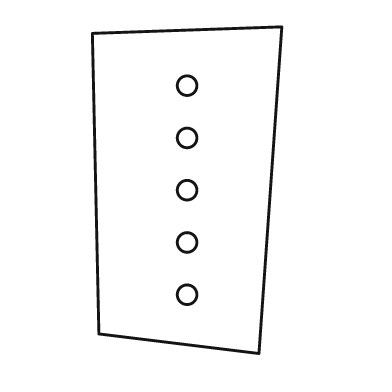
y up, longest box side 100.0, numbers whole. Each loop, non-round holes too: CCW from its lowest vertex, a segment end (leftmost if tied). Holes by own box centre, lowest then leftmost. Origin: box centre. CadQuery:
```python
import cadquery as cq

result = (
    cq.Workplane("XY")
    .moveTo(22.0, -50.0)
    .lineTo(29.0, 50.0)
    .lineTo(-29.0, 48.0)
    .lineTo(-27.0, -44.0)
    .close()
    .moveTo(0.0, -32.0)
    .circle(3.0)
    .moveTo(0.0, -16.0)
    .circle(3.0)
    .moveTo(0.0, 0.0)
    .circle(3.0)
    .moveTo(0.0, 16.0)
    .circle(3.0)
    .moveTo(0.0, 32.0)
    .circle(3.0)
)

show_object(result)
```